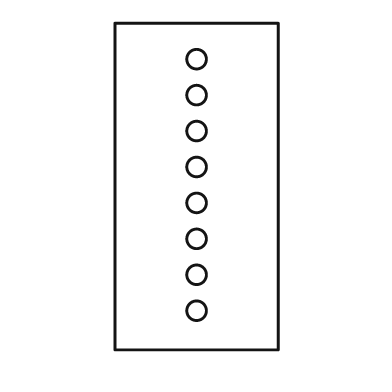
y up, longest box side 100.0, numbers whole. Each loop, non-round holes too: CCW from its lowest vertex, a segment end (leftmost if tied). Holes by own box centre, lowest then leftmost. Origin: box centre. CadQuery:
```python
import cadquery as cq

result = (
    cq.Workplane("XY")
    .moveTo(-25.0, -50.0)
    .lineTo(25.0, -50.0)
    .lineTo(25.0, 50.0)
    .lineTo(-25.0, 50.0)
    .close()
    .moveTo(0.0, -38.0)
    .circle(3.0)
    .moveTo(0.0, -27.0)
    .circle(3.0)
    .moveTo(0.0, -16.0)
    .circle(3.0)
    .moveTo(0.0, -5.0)
    .circle(3.0)
    .moveTo(0.0, 6.0)
    .circle(3.0)
    .moveTo(0.0, 17.0)
    .circle(3.0)
    .moveTo(0.0, 28.0)
    .circle(3.0)
    .moveTo(0.0, 39.0)
    .circle(3.0)
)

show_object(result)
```